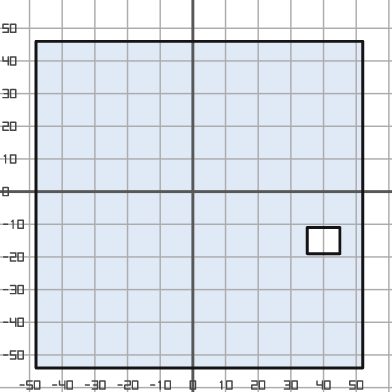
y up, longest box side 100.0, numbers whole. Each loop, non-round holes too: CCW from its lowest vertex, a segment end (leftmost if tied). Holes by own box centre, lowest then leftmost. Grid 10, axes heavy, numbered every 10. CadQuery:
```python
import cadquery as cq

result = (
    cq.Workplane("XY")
    .moveTo(-48.0, -54.0)
    .lineTo(52.0, -54.0)
    .lineTo(52.0, 46.0)
    .lineTo(-48.0, 46.0)
    .close()
    .moveTo(35.0, -19.0)
    .lineTo(45.0, -19.0)
    .lineTo(45.0, -11.0)
    .lineTo(35.0, -11.0)
    .close()
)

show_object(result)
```